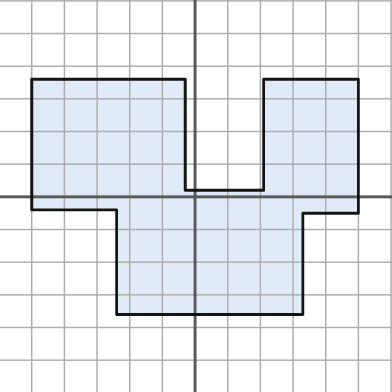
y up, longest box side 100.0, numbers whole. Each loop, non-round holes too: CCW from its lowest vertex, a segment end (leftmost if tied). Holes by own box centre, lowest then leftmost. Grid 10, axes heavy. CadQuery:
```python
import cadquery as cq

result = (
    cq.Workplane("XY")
    .moveTo(-24.0, -36.0)
    .lineTo(33.0, -36.0)
    .lineTo(33.0, -5.0)
    .lineTo(50.0, -5.0)
    .lineTo(50.0, 36.0)
    .lineTo(21.0, 36.0)
    .lineTo(21.0, 2.0)
    .lineTo(-3.0, 2.0)
    .lineTo(-3.0, 36.0)
    .lineTo(-50.0, 36.0)
    .lineTo(-50.0, -4.0)
    .lineTo(-24.0, -4.0)
    .close()
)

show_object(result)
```